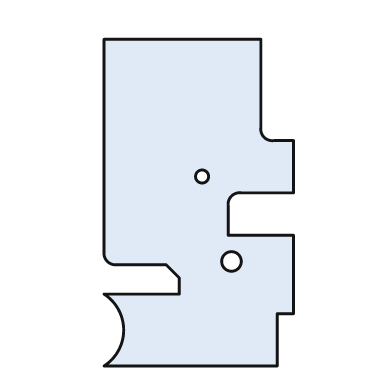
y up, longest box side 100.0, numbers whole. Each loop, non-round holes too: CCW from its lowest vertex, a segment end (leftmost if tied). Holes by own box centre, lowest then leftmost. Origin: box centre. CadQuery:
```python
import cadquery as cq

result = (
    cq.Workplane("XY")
    .moveTo(-29.0, -50.0)
    .lineTo(24.0, -50.0)
    .lineTo(24.0, -34.0)
    .lineTo(29.0, -34.0)
    .lineTo(29.0, -10.0)
    .lineTo(9.0, -10.0)
    .lineTo(9.0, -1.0)
    .threePointArc((10.0, 2.0), (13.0, 3.0))
    .lineTo(29.0, 3.0)
    .lineTo(29.0, 19.0)
    .lineTo(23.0, 19.0)
    .threePointArc((20.0, 20.0), (19.0, 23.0))
    .lineTo(19.0, 50.0)
    .lineTo(-29.0, 50.0)
    .lineTo(-29.0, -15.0)
    .threePointArc((-28.0, -18.0), (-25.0, -19.0))
    .lineTo(-10.0, -19.0)
    .lineTo(-6.0, -23.0)
    .lineTo(-6.0, -28.0)
    .lineTo(-29.0, -28.0)
    .threePointArc((-23.0, -39.0), (-29.0, -50.0))
    .close()
    .moveTo(10.0, -18.0)
    .circle(3.0)
    .moveTo(1.0, 8.0)
    .circle(2.0)
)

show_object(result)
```